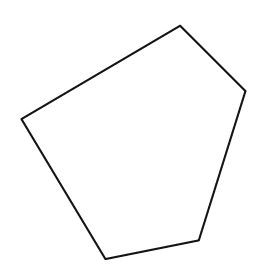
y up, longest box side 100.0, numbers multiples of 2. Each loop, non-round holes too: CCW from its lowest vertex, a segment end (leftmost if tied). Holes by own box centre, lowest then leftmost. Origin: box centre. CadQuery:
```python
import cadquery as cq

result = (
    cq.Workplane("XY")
    .moveTo(-12.0, -50.0)
    .lineTo(28.0, -42.0)
    .lineTo(48.0, 22.0)
    .lineTo(20.0, 50.0)
    .lineTo(-48.0, 10.0)
    .close()
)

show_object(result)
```